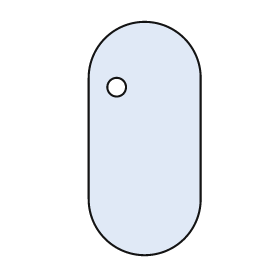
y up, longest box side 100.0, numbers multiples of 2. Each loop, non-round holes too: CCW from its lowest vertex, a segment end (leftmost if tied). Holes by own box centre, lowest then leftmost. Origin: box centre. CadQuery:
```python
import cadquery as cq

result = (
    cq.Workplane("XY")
    .moveTo(-24.0, -26.0)
    .threePointArc((0.0, -50.0), (24.0, -26.0))
    .lineTo(24.0, 26.0)
    .threePointArc((0.0, 50.0), (-24.0, 26.0))
    .close()
    .moveTo(-12.0, 22.0)
    .circle(4.0)
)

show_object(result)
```